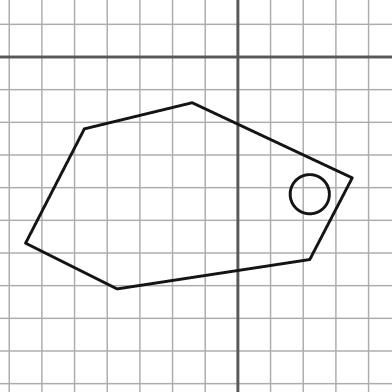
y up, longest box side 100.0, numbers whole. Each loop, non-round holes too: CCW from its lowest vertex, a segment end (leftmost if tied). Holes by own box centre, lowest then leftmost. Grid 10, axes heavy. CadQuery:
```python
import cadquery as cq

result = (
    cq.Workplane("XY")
    .moveTo(-37.0, -71.0)
    .lineTo(22.0, -62.0)
    .lineTo(35.0, -37.0)
    .lineTo(-14.0, -14.0)
    .lineTo(-47.0, -22.0)
    .lineTo(-65.0, -57.0)
    .close()
    .moveTo(22.0, -42.0)
    .circle(6.0)
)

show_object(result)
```